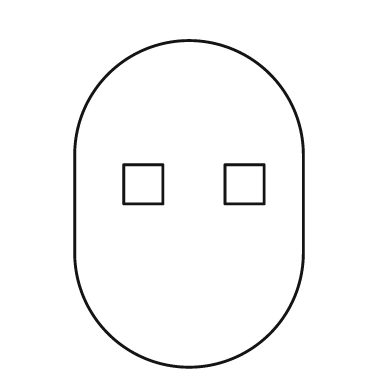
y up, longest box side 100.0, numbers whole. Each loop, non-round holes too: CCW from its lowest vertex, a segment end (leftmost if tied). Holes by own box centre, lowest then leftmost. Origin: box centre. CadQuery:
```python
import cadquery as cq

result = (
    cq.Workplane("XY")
    .moveTo(-35.0, -15.0)
    .threePointArc((0.0, -50.0), (35.0, -15.0))
    .lineTo(35.0, 15.0)
    .threePointArc((0.0, 50.0), (-35.0, 15.0))
    .close()
    .moveTo(-20.0, 0.0)
    .lineTo(-8.0, 0.0)
    .lineTo(-8.0, 12.0)
    .lineTo(-20.0, 12.0)
    .close()
    .moveTo(11.0, 0.0)
    .lineTo(23.0, 0.0)
    .lineTo(23.0, 12.0)
    .lineTo(11.0, 12.0)
    .close()
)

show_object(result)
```